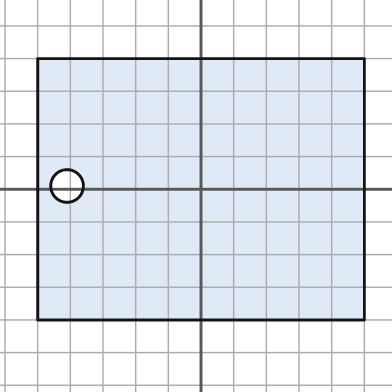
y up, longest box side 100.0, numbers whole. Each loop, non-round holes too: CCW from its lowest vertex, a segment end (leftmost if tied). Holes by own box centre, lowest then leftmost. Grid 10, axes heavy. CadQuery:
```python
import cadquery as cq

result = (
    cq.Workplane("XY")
    .moveTo(-50.0, -40.0)
    .lineTo(50.0, -40.0)
    .lineTo(50.0, 40.0)
    .lineTo(-50.0, 40.0)
    .close()
    .moveTo(-41.0, 1.0)
    .circle(5.0)
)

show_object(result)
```